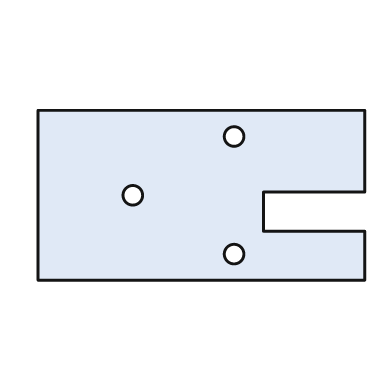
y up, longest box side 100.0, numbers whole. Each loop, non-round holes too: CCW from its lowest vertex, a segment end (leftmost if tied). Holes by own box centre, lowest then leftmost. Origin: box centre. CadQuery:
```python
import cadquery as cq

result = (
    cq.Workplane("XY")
    .moveTo(-50.0, -26.0)
    .lineTo(50.0, -26.0)
    .lineTo(50.0, -11.0)
    .lineTo(19.0, -11.0)
    .lineTo(19.0, 1.0)
    .lineTo(50.0, 1.0)
    .lineTo(50.0, 26.0)
    .lineTo(-50.0, 26.0)
    .close()
    .moveTo(10.0, -18.0)
    .circle(3.0)
    .moveTo(-21.0, 0.0)
    .circle(3.0)
    .moveTo(10.0, 18.0)
    .circle(3.0)
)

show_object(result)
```